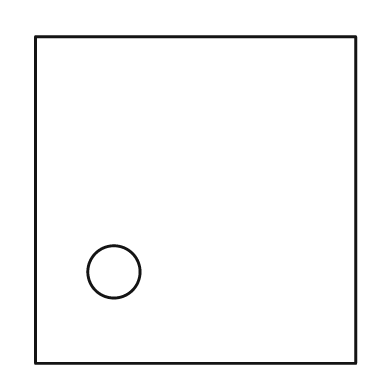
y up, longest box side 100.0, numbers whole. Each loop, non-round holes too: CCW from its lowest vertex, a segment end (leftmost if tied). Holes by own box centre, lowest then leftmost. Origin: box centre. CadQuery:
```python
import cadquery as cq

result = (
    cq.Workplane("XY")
    .moveTo(-49.0, -50.0)
    .lineTo(49.0, -50.0)
    .lineTo(49.0, 50.0)
    .lineTo(-49.0, 50.0)
    .close()
    .moveTo(-25.0, -22.0)
    .circle(8.0)
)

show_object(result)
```